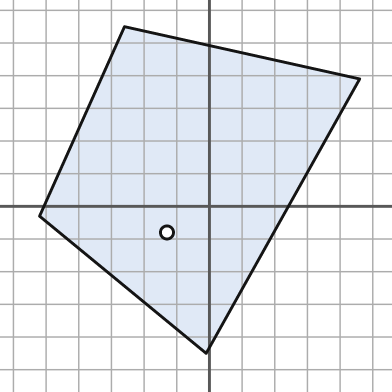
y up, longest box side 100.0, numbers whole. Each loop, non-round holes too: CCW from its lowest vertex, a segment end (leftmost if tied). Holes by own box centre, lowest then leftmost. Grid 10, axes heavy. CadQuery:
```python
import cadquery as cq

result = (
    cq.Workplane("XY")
    .moveTo(-1.0, -45.0)
    .lineTo(46.0, 39.0)
    .lineTo(-26.0, 55.0)
    .lineTo(-52.0, -3.0)
    .close()
    .moveTo(-13.0, -8.0)
    .circle(2.0)
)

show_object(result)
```